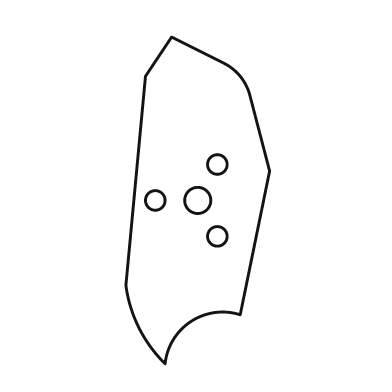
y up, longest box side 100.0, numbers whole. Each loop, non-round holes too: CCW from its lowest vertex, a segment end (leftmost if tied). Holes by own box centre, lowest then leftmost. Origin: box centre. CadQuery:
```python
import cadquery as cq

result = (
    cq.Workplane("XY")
    .moveTo(-10.0, -50.0)
    .threePointArc((-2.0, -37.0), (13.0, -35.0))
    .lineTo(22.0, 9.0)
    .lineTo(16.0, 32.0)
    .threePointArc((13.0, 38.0), (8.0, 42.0))
    .lineTo(-8.0, 50.0)
    .lineTo(-16.0, 38.0)
    .lineTo(-22.0, -26.0)
    .threePointArc((-18.0, -39.0), (-10.0, -50.0))
    .close()
    .moveTo(6.0, -11.0)
    .circle(3.0)
    .moveTo(-13.0, 0.0)
    .circle(3.0)
    .moveTo(0.0, 0.0)
    .circle(4.0)
    .moveTo(6.0, 11.0)
    .circle(3.0)
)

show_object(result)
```